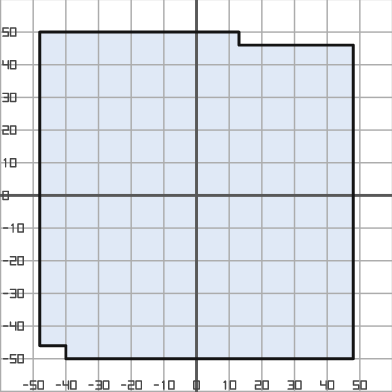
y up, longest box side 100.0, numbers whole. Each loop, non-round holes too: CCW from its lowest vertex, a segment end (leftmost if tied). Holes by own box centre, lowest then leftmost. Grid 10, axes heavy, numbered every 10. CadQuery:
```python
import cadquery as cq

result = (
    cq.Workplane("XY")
    .moveTo(-40.0, -50.0)
    .lineTo(48.0, -50.0)
    .lineTo(48.0, 46.0)
    .lineTo(13.0, 46.0)
    .lineTo(13.0, 50.0)
    .lineTo(-48.0, 50.0)
    .lineTo(-48.0, -46.0)
    .lineTo(-40.0, -46.0)
    .close()
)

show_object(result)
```